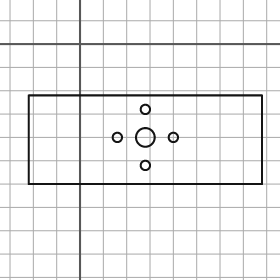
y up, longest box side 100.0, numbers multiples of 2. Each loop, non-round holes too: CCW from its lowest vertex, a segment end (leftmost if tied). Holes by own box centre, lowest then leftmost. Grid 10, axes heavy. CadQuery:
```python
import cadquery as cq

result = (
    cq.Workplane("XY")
    .moveTo(-22.0, -60.0)
    .lineTo(78.0, -60.0)
    .lineTo(78.0, -22.0)
    .lineTo(-22.0, -22.0)
    .close()
    .moveTo(28.0, -52.0)
    .circle(2.0)
    .moveTo(16.0, -40.0)
    .circle(2.0)
    .moveTo(28.0, -40.0)
    .circle(4.0)
    .moveTo(40.0, -40.0)
    .circle(2.0)
    .moveTo(28.0, -28.0)
    .circle(2.0)
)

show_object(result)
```